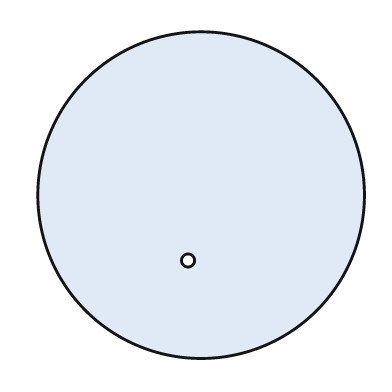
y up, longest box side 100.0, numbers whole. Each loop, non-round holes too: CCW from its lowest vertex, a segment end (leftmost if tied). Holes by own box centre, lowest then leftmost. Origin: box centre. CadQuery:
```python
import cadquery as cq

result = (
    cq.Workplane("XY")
    .moveTo(0.0, 0.0)
    .circle(50.0)
    .moveTo(-4.0, -20.0)
    .circle(2.0)
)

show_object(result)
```